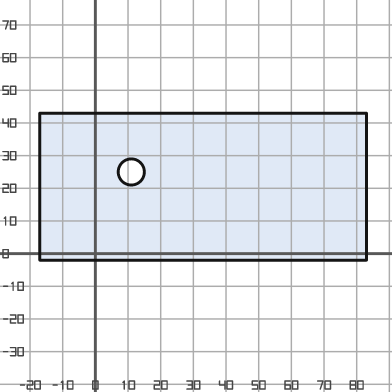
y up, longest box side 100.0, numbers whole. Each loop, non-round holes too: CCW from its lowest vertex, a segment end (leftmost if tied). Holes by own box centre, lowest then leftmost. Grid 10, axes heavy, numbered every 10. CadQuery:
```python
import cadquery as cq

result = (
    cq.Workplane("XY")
    .moveTo(-17.0, -2.0)
    .lineTo(83.0, -2.0)
    .lineTo(83.0, 43.0)
    .lineTo(-17.0, 43.0)
    .close()
    .moveTo(11.0, 25.0)
    .circle(4.0)
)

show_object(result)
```